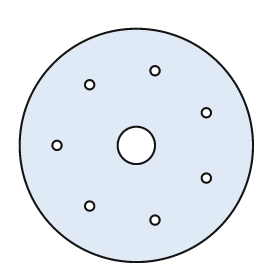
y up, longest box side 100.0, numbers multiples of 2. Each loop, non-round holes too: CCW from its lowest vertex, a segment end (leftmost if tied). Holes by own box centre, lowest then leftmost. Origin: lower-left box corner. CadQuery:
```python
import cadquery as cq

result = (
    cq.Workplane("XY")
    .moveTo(50.0, 50.0)
    .circle(50.0)
    .moveTo(58.0, 18.0)
    .circle(2.0)
    .moveTo(30.0, 24.0)
    .circle(2.0)
    .moveTo(80.0, 36.0)
    .circle(2.0)
    .moveTo(16.0, 50.0)
    .circle(2.0)
    .moveTo(50.0, 50.0)
    .circle(8.0)
    .moveTo(80.0, 64.0)
    .circle(2.0)
    .moveTo(30.0, 76.0)
    .circle(2.0)
    .moveTo(58.0, 82.0)
    .circle(2.0)
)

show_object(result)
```